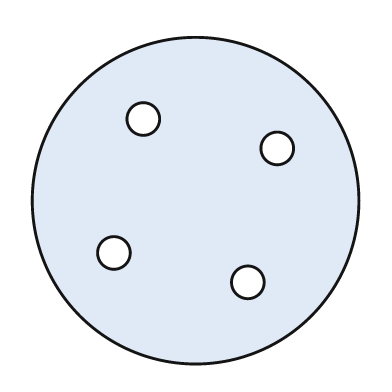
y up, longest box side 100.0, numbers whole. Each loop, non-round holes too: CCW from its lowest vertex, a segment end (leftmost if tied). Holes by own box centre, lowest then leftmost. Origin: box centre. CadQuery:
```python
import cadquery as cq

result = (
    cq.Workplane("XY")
    .moveTo(0.0, 0.0)
    .circle(50.0)
    .moveTo(16.0, -25.0)
    .circle(5.0)
    .moveTo(-25.0, -16.0)
    .circle(5.0)
    .moveTo(25.0, 16.0)
    .circle(5.0)
    .moveTo(-16.0, 25.0)
    .circle(5.0)
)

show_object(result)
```